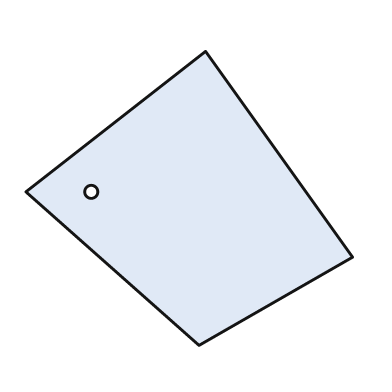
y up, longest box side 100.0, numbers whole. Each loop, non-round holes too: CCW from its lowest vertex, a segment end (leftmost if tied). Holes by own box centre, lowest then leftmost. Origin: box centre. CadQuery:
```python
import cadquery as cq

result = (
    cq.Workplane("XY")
    .moveTo(3.0, -45.0)
    .lineTo(50.0, -18.0)
    .lineTo(5.0, 45.0)
    .lineTo(-50.0, 2.0)
    .close()
    .moveTo(-30.0, 2.0)
    .circle(2.0)
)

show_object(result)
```